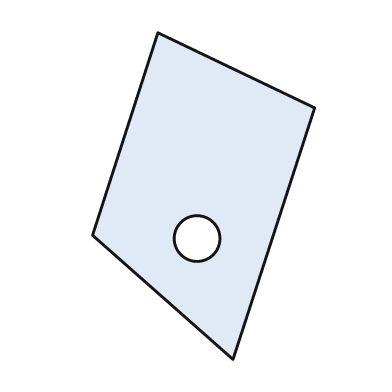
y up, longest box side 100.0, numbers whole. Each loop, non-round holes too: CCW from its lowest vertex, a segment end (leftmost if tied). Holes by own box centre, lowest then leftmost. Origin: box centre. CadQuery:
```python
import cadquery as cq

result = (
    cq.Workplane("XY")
    .moveTo(9.0, -50.0)
    .lineTo(34.0, 27.0)
    .lineTo(-14.0, 50.0)
    .lineTo(-34.0, -12.0)
    .close()
    .moveTo(-2.0, -13.0)
    .circle(7.0)
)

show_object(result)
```